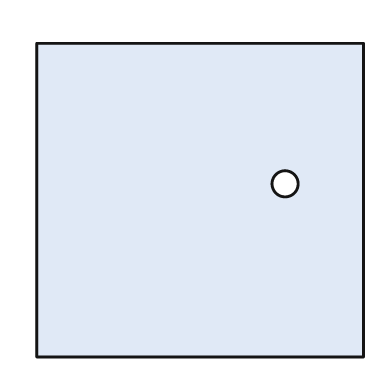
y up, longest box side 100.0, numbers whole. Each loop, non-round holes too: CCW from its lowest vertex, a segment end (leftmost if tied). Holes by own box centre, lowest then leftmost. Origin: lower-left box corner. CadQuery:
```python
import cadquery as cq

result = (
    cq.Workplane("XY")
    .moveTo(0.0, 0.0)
    .lineTo(100.0, 0.0)
    .lineTo(100.0, 96.0)
    .lineTo(0.0, 96.0)
    .close()
    .moveTo(76.0, 53.0)
    .circle(4.0)
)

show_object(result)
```